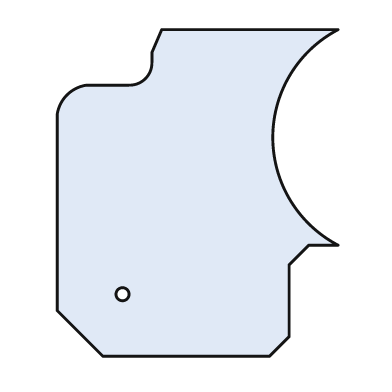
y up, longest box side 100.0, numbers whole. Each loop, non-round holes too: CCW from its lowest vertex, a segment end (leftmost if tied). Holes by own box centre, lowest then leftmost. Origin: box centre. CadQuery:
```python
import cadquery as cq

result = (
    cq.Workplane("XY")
    .moveTo(-29.0, -50.0)
    .lineTo(22.0, -50.0)
    .lineTo(28.0, -44.0)
    .lineTo(28.0, -22.0)
    .lineTo(34.0, -16.0)
    .lineTo(43.0, -16.0)
    .threePointArc((23.0, 17.0), (43.0, 50.0))
    .lineTo(-11.0, 50.0)
    .lineTo(-14.0, 43.0)
    .lineTo(-14.0, 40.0)
    .threePointArc((-16.0, 35.0), (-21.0, 33.0))
    .lineTo(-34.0, 33.0)
    .threePointArc((-40.0, 30.0), (-43.0, 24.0))
    .lineTo(-43.0, -36.0)
    .close()
    .moveTo(-23.0, -31.0)
    .circle(2.0)
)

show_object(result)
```